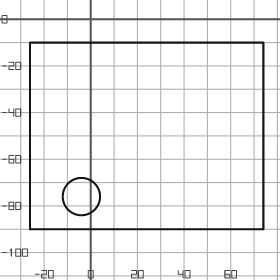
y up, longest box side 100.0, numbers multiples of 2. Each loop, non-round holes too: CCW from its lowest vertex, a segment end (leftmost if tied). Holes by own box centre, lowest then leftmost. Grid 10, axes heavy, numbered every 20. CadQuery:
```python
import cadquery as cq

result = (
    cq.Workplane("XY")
    .moveTo(-26.0, -90.0)
    .lineTo(74.0, -90.0)
    .lineTo(74.0, -10.0)
    .lineTo(-26.0, -10.0)
    .close()
    .moveTo(-4.0, -76.0)
    .circle(8.0)
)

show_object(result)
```